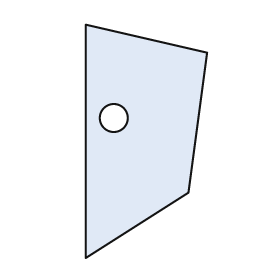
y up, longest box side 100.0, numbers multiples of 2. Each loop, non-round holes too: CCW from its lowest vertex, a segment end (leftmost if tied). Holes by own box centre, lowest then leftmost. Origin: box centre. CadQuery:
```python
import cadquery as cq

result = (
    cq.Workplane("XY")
    .moveTo(-26.0, -50.0)
    .lineTo(18.0, -22.0)
    .lineTo(26.0, 38.0)
    .lineTo(-26.0, 50.0)
    .close()
    .moveTo(-14.0, 10.0)
    .circle(6.0)
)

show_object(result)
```